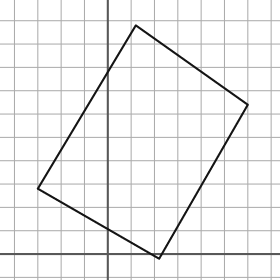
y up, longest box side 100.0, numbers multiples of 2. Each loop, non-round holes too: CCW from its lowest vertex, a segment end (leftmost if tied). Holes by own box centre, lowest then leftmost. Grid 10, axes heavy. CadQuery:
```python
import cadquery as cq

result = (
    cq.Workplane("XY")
    .moveTo(22.0, -2.0)
    .lineTo(60.0, 64.0)
    .lineTo(12.0, 98.0)
    .lineTo(-30.0, 28.0)
    .close()
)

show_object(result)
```